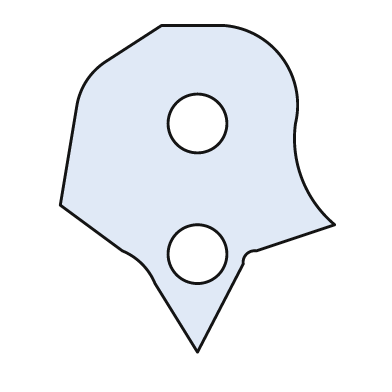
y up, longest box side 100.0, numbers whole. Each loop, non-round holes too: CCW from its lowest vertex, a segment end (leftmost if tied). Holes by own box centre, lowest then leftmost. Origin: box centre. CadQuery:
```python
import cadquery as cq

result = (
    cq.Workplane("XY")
    .moveTo(0.0, -50.0)
    .lineTo(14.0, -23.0)
    .threePointArc((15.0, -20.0), (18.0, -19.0))
    .lineTo(42.0, -11.0)
    .threePointArc((32.0, 3.0), (30.0, 20.0))
    .threePointArc((26.0, 40.0), (8.0, 50.0))
    .lineTo(-11.0, 50.0)
    .lineTo(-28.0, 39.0)
    .threePointArc((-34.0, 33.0), (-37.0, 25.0))
    .lineTo(-42.0, -5.0)
    .lineTo(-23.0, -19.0)
    .threePointArc((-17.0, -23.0), (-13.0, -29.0))
    .close()
    .moveTo(0.0, -20.0)
    .circle(9.0)
    .moveTo(0.0, 20.0)
    .circle(9.0)
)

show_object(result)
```